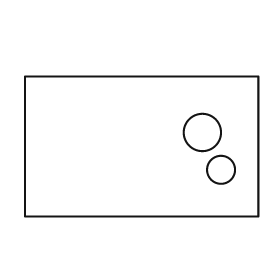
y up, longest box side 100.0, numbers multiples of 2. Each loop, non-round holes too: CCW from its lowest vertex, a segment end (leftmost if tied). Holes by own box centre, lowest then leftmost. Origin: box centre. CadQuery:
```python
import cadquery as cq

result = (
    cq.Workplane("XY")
    .moveTo(-50.0, -30.0)
    .lineTo(50.0, -30.0)
    .lineTo(50.0, 30.0)
    .lineTo(-50.0, 30.0)
    .close()
    .moveTo(34.0, -10.0)
    .circle(6.0)
    .moveTo(26.0, 6.0)
    .circle(8.0)
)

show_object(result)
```